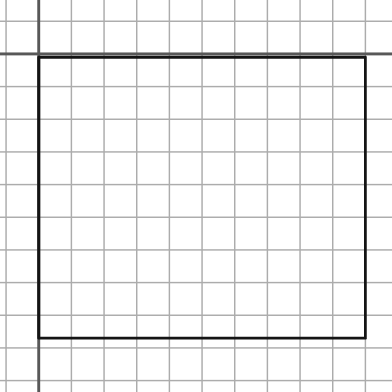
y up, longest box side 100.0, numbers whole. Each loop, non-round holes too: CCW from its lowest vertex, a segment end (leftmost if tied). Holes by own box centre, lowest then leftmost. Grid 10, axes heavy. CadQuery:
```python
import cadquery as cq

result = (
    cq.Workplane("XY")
    .moveTo(0.0, -87.0)
    .lineTo(100.0, -87.0)
    .lineTo(100.0, -1.0)
    .lineTo(0.0, -1.0)
    .close()
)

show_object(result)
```